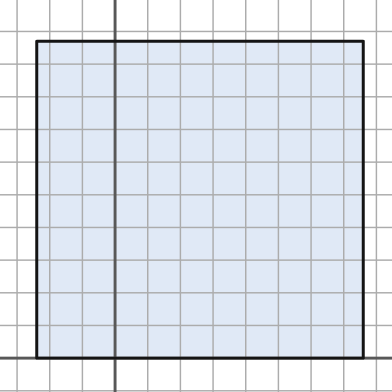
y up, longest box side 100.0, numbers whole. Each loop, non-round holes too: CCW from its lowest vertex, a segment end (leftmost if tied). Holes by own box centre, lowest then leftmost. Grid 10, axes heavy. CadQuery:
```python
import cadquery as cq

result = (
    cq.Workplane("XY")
    .moveTo(-24.0, 0.0)
    .lineTo(76.0, 0.0)
    .lineTo(76.0, 97.0)
    .lineTo(-24.0, 97.0)
    .close()
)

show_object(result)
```